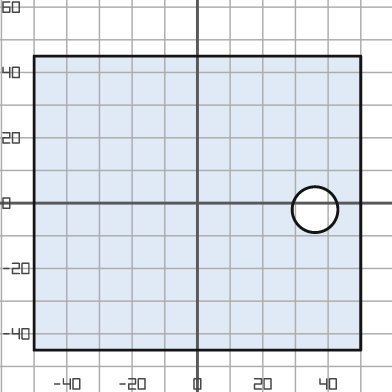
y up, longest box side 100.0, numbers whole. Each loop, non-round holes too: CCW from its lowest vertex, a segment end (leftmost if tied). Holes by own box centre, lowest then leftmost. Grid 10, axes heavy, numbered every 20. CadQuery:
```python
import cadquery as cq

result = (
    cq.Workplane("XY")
    .moveTo(-50.0, -45.0)
    .lineTo(50.0, -45.0)
    .lineTo(50.0, 45.0)
    .lineTo(-50.0, 45.0)
    .close()
    .moveTo(36.0, -2.0)
    .circle(7.0)
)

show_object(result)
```